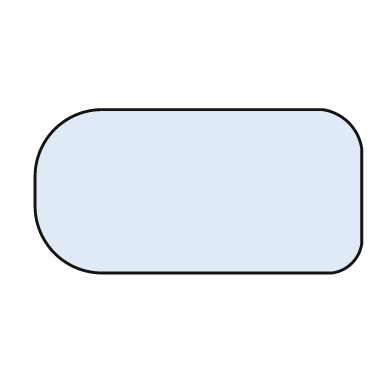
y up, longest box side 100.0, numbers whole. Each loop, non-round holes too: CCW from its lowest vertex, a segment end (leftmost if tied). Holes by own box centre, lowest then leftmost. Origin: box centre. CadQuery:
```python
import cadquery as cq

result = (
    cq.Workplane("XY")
    .moveTo(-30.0, -25.0)
    .lineTo(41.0, -25.0)
    .threePointArc((47.0, -22.0), (50.0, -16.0))
    .lineTo(50.0, 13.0)
    .threePointArc((46.0, 21.0), (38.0, 25.0))
    .lineTo(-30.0, 25.0)
    .threePointArc((-44.0, 19.0), (-50.0, 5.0))
    .lineTo(-50.0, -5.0)
    .threePointArc((-44.0, -19.0), (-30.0, -25.0))
    .close()
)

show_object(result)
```